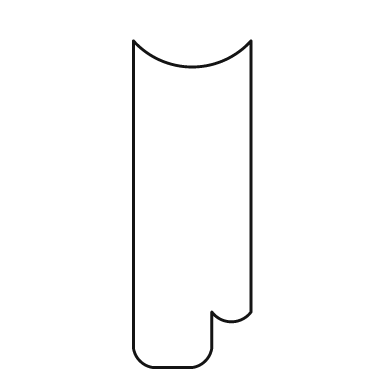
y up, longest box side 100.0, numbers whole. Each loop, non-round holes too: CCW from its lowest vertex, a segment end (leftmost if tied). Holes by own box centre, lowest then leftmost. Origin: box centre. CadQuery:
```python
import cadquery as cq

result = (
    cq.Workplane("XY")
    .moveTo(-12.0, -50.0)
    .lineTo(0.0, -50.0)
    .threePointArc((4.0, -48.0), (6.0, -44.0))
    .lineTo(6.0, -33.0)
    .threePointArc((12.0, -36.0), (18.0, -33.0))
    .lineTo(18.0, 50.0)
    .threePointArc((0.0, 42.0), (-18.0, 50.0))
    .lineTo(-18.0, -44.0)
    .threePointArc((-16.0, -48.0), (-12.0, -50.0))
    .close()
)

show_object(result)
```